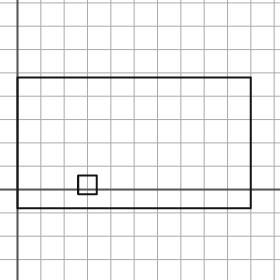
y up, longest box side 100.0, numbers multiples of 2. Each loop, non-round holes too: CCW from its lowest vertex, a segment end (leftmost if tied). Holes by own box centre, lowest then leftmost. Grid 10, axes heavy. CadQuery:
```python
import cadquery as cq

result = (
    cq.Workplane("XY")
    .moveTo(0.0, -8.0)
    .lineTo(100.0, -8.0)
    .lineTo(100.0, 48.0)
    .lineTo(0.0, 48.0)
    .close()
    .moveTo(26.0, -2.0)
    .lineTo(34.0, -2.0)
    .lineTo(34.0, 6.0)
    .lineTo(26.0, 6.0)
    .close()
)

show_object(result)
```